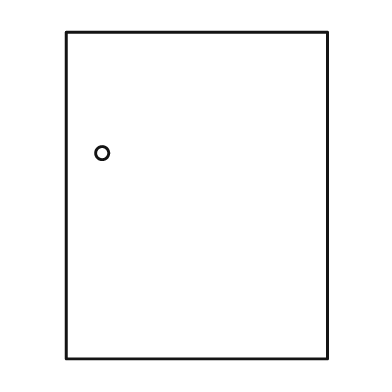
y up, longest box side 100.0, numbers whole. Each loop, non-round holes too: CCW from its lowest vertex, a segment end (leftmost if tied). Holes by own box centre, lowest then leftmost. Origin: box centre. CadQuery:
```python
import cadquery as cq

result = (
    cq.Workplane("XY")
    .moveTo(-40.0, -50.0)
    .lineTo(40.0, -50.0)
    .lineTo(40.0, 50.0)
    .lineTo(-40.0, 50.0)
    .close()
    .moveTo(-29.0, 13.0)
    .circle(2.0)
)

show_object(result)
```